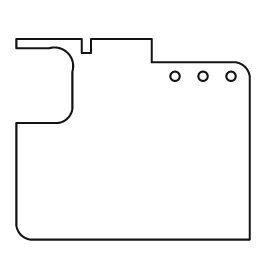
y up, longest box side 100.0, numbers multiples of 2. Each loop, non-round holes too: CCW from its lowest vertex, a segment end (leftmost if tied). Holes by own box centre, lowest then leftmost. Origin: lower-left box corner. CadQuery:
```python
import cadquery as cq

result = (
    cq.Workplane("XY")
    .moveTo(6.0, 0.0)
    .lineTo(100.0, 0.0)
    .lineTo(100.0, 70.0)
    .threePointArc((98.0, 74.0), (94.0, 76.0))
    .lineTo(58.0, 76.0)
    .lineTo(58.0, 86.0)
    .lineTo(32.0, 86.0)
    .lineTo(32.0, 80.0)
    .lineTo(28.0, 80.0)
    .lineTo(28.0, 86.0)
    .lineTo(0.0, 86.0)
    .lineTo(0.0, 82.0)
    .lineTo(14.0, 82.0)
    .threePointArc((22.0, 80.0), (24.0, 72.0))
    .lineTo(24.0, 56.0)
    .threePointArc((22.0, 52.0), (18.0, 50.0))
    .lineTo(0.0, 50.0)
    .lineTo(0.0, 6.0)
    .threePointArc((2.0, 2.0), (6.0, 0.0))
    .close()
    .moveTo(68.0, 70.0)
    .circle(2.0)
    .moveTo(80.0, 70.0)
    .circle(2.0)
    .moveTo(92.0, 70.0)
    .circle(2.0)
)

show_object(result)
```